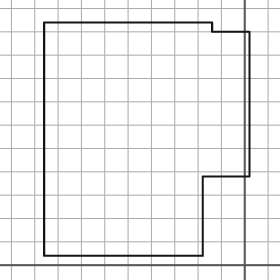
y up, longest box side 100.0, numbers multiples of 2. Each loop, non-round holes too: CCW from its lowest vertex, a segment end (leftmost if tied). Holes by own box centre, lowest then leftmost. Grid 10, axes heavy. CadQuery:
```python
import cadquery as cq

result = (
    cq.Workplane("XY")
    .moveTo(-86.0, 4.0)
    .lineTo(-18.0, 4.0)
    .lineTo(-18.0, 38.0)
    .lineTo(2.0, 38.0)
    .lineTo(2.0, 100.0)
    .lineTo(-14.0, 100.0)
    .lineTo(-14.0, 104.0)
    .lineTo(-86.0, 104.0)
    .close()
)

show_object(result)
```